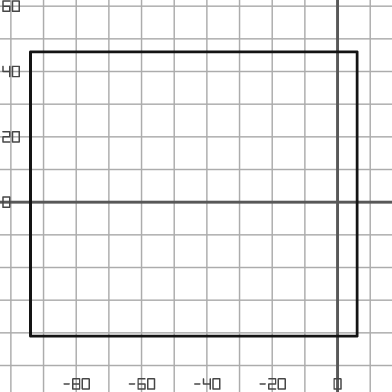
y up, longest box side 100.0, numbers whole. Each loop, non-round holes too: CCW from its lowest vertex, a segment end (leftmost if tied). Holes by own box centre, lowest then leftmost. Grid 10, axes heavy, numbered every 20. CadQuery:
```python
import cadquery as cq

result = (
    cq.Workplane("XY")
    .moveTo(-94.0, -41.0)
    .lineTo(6.0, -41.0)
    .lineTo(6.0, 46.0)
    .lineTo(-94.0, 46.0)
    .close()
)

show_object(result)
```